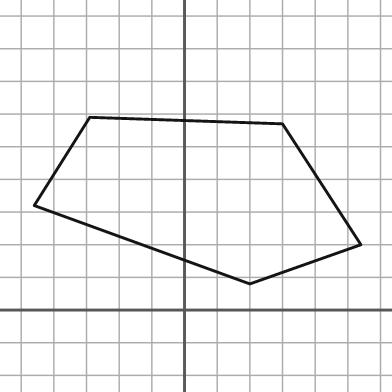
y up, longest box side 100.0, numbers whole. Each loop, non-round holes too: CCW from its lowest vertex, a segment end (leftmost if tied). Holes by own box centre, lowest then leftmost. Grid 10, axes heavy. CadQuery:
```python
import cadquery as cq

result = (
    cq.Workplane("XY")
    .moveTo(20.0, 8.0)
    .lineTo(54.0, 20.0)
    .lineTo(30.0, 57.0)
    .lineTo(-29.0, 59.0)
    .lineTo(-46.0, 32.0)
    .close()
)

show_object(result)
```